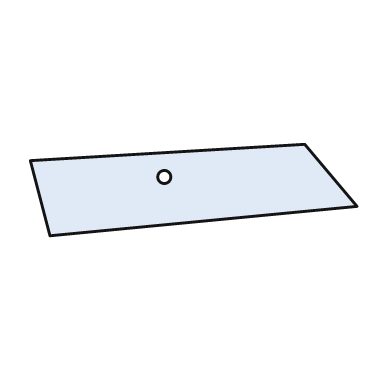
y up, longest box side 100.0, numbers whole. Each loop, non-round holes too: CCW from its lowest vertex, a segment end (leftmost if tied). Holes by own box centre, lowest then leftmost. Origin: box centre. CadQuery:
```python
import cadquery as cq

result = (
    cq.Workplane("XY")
    .moveTo(-44.0, -14.0)
    .lineTo(50.0, -5.0)
    .lineTo(34.0, 14.0)
    .lineTo(-50.0, 9.0)
    .close()
    .moveTo(-9.0, 4.0)
    .circle(2.0)
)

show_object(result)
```